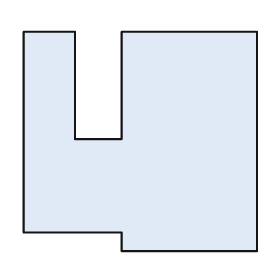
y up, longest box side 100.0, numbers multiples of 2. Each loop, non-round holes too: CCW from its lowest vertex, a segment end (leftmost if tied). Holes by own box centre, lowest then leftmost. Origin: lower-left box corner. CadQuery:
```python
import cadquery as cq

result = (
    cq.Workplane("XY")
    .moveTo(42.0, 0.0)
    .lineTo(100.0, 0.0)
    .lineTo(100.0, 94.0)
    .lineTo(42.0, 94.0)
    .lineTo(42.0, 48.0)
    .lineTo(22.0, 48.0)
    .lineTo(22.0, 94.0)
    .lineTo(0.0, 94.0)
    .lineTo(0.0, 8.0)
    .lineTo(42.0, 8.0)
    .close()
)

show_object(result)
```